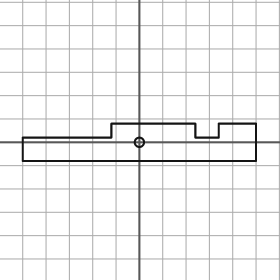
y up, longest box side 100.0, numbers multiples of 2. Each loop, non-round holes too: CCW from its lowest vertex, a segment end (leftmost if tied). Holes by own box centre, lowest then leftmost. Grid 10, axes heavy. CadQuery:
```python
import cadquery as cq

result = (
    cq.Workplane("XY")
    .moveTo(-50.0, -8.0)
    .lineTo(50.0, -8.0)
    .lineTo(50.0, 8.0)
    .lineTo(34.0, 8.0)
    .lineTo(34.0, 2.0)
    .lineTo(24.0, 2.0)
    .lineTo(24.0, 8.0)
    .lineTo(-12.0, 8.0)
    .lineTo(-12.0, 2.0)
    .lineTo(-50.0, 2.0)
    .close()
    .moveTo(0.0, 0.0)
    .circle(2.0)
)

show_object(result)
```